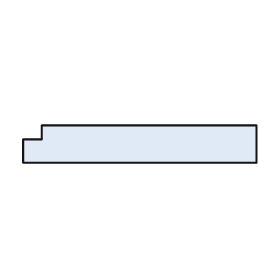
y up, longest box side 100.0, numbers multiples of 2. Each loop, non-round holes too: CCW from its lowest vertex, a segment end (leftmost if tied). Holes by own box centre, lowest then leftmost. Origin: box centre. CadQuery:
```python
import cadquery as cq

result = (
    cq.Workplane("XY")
    .moveTo(-50.0, -8.0)
    .lineTo(50.0, -8.0)
    .lineTo(50.0, 8.0)
    .lineTo(-42.0, 8.0)
    .lineTo(-42.0, 2.0)
    .lineTo(-50.0, 2.0)
    .close()
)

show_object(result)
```